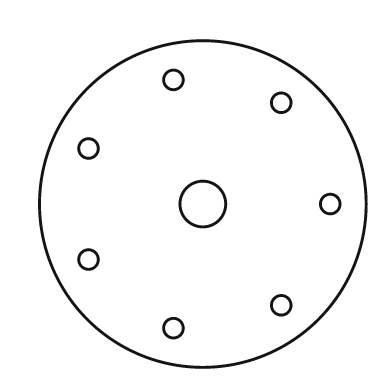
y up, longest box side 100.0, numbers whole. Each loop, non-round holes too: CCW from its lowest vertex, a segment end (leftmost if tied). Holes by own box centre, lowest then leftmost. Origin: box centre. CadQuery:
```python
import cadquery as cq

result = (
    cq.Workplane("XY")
    .moveTo(0.0, 0.0)
    .circle(50.0)
    .moveTo(-9.0, -38.0)
    .circle(3.0)
    .moveTo(24.0, -31.0)
    .circle(3.0)
    .moveTo(-35.0, -17.0)
    .circle(3.0)
    .moveTo(0.0, 0.0)
    .circle(7.0)
    .moveTo(39.0, 0.0)
    .circle(3.0)
    .moveTo(-35.0, 17.0)
    .circle(3.0)
    .moveTo(24.0, 31.0)
    .circle(3.0)
    .moveTo(-9.0, 38.0)
    .circle(3.0)
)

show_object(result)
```